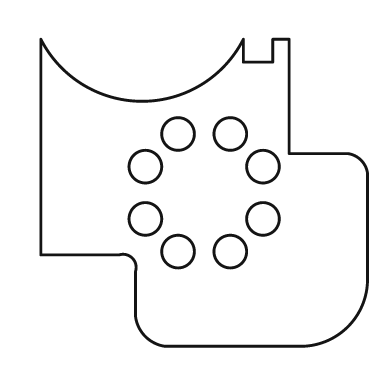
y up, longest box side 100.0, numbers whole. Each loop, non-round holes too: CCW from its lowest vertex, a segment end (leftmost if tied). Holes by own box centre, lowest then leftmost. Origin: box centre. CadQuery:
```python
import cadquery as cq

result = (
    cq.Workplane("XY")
    .moveTo(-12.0, -47.0)
    .lineTo(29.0, -47.0)
    .threePointArc((44.0, -41.0), (50.0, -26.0))
    .lineTo(50.0, 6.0)
    .threePointArc((48.0, 10.0), (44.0, 12.0))
    .lineTo(26.0, 12.0)
    .lineTo(26.0, 47.0)
    .lineTo(21.0, 47.0)
    .lineTo(21.0, 40.0)
    .lineTo(12.0, 40.0)
    .lineTo(12.0, 47.0)
    .threePointArc((-19.0, 28.0), (-50.0, 47.0))
    .lineTo(-50.0, -19.0)
    .lineTo(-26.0, -19.0)
    .threePointArc((-22.0, -20.0), (-21.0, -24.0))
    .lineTo(-21.0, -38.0)
    .threePointArc((-18.0, -44.0), (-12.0, -47.0))
    .close()
    .moveTo(-8.0, -18.0)
    .circle(5.0)
    .moveTo(8.0, -18.0)
    .circle(5.0)
    .moveTo(-18.0, -8.0)
    .circle(5.0)
    .moveTo(18.0, -8.0)
    .circle(5.0)
    .moveTo(-18.0, 8.0)
    .circle(5.0)
    .moveTo(18.0, 8.0)
    .circle(5.0)
    .moveTo(-8.0, 18.0)
    .circle(5.0)
    .moveTo(8.0, 18.0)
    .circle(5.0)
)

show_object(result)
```